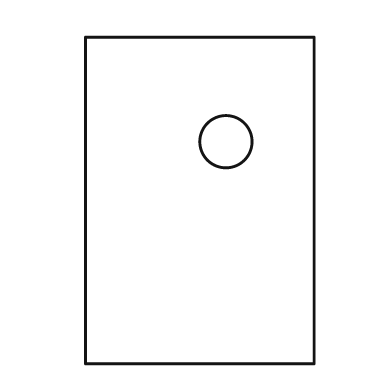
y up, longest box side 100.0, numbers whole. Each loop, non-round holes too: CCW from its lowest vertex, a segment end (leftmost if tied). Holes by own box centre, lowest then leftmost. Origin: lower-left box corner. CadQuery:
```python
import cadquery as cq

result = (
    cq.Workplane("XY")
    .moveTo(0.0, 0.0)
    .lineTo(70.0, 0.0)
    .lineTo(70.0, 100.0)
    .lineTo(0.0, 100.0)
    .close()
    .moveTo(43.0, 68.0)
    .circle(8.0)
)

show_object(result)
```